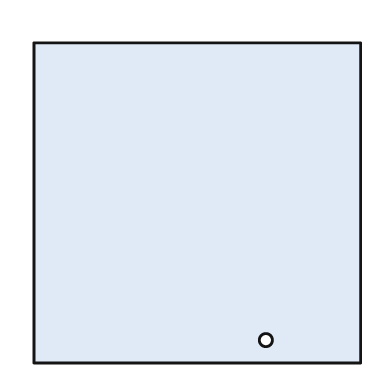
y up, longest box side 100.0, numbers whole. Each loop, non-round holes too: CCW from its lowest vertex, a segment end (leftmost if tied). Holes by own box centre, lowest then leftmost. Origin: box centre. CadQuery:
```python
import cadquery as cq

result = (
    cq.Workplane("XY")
    .moveTo(-50.0, -49.0)
    .lineTo(50.0, -49.0)
    .lineTo(50.0, 49.0)
    .lineTo(-50.0, 49.0)
    .close()
    .moveTo(21.0, -42.0)
    .circle(2.0)
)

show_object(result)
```